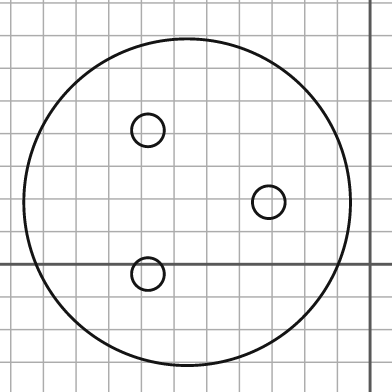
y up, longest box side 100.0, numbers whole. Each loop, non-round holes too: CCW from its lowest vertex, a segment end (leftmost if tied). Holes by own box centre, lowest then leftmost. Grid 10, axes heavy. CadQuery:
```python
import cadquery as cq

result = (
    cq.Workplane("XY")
    .moveTo(-56.0, 19.0)
    .circle(50.0)
    .moveTo(-68.0, -3.0)
    .circle(5.0)
    .moveTo(-31.0, 19.0)
    .circle(5.0)
    .moveTo(-68.0, 41.0)
    .circle(5.0)
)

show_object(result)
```